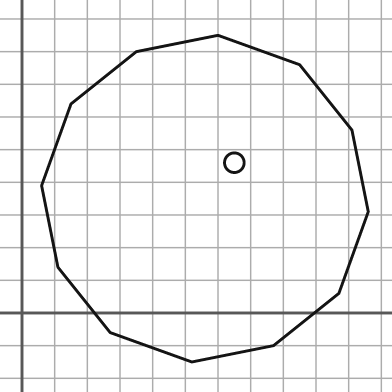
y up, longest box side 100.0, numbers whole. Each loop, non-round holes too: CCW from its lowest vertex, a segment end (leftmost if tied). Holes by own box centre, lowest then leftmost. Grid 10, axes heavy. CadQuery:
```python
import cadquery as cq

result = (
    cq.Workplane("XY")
    .moveTo(52.0, -15.0)
    .lineTo(77.0, -10.0)
    .lineTo(97.0, 6.0)
    .lineTo(106.0, 31.0)
    .lineTo(101.0, 56.0)
    .lineTo(85.0, 76.0)
    .lineTo(60.0, 85.0)
    .lineTo(35.0, 80.0)
    .lineTo(15.0, 64.0)
    .lineTo(6.0, 39.0)
    .lineTo(11.0, 14.0)
    .lineTo(27.0, -6.0)
    .close()
    .moveTo(65.0, 46.0)
    .circle(3.0)
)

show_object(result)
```